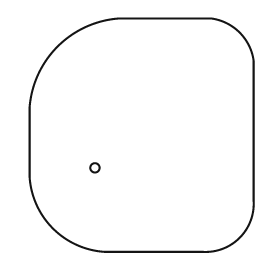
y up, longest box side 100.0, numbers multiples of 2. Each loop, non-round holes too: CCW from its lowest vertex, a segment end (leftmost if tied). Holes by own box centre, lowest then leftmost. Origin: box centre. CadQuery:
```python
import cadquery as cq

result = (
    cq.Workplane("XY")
    .moveTo(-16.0, -50.0)
    .lineTo(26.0, -50.0)
    .threePointArc((42.0, -44.0), (48.0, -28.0))
    .lineTo(48.0, 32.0)
    .threePointArc((42.0, 44.0), (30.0, 50.0))
    .lineTo(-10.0, 50.0)
    .threePointArc((-36.0, 38.0), (-48.0, 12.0))
    .lineTo(-48.0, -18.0)
    .threePointArc((-38.0, -40.0), (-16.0, -50.0))
    .close()
    .moveTo(-20.0, -14.0)
    .circle(2.0)
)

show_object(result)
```